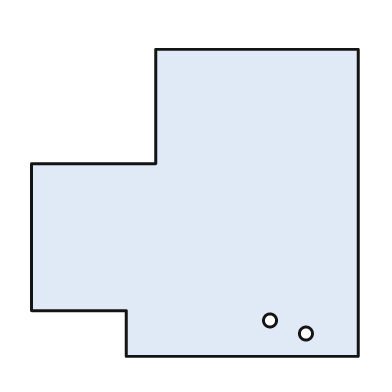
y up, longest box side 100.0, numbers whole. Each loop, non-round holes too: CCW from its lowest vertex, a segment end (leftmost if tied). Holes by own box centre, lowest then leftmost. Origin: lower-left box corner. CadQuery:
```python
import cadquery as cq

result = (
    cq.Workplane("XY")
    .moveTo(29.0, 0.0)
    .lineTo(100.0, 0.0)
    .lineTo(100.0, 94.0)
    .lineTo(38.0, 94.0)
    .lineTo(38.0, 59.0)
    .lineTo(0.0, 59.0)
    .lineTo(0.0, 14.0)
    .lineTo(29.0, 14.0)
    .close()
    .moveTo(84.0, 7.0)
    .circle(2.0)
    .moveTo(73.0, 11.0)
    .circle(2.0)
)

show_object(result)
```